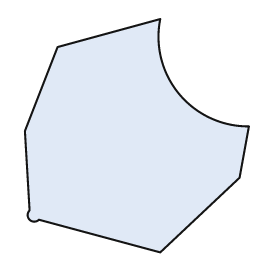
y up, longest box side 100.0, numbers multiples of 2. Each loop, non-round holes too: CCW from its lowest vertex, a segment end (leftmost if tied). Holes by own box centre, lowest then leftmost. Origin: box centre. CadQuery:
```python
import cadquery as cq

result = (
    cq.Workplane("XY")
    .moveTo(10.0, -50.0)
    .lineTo(44.0, -18.0)
    .lineTo(48.0, 4.0)
    .threePointArc((18.0, 18.0), (10.0, 50.0))
    .lineTo(-34.0, 38.0)
    .lineTo(-48.0, 2.0)
    .lineTo(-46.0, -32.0)
    .threePointArc((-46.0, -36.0), (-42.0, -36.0))
    .close()
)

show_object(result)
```